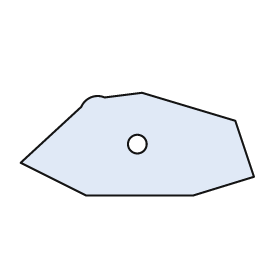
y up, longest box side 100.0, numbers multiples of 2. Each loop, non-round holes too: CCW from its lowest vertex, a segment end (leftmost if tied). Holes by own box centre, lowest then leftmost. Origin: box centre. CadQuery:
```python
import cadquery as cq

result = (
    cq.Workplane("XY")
    .moveTo(-22.0, -22.0)
    .lineTo(24.0, -22.0)
    .lineTo(50.0, -14.0)
    .lineTo(42.0, 10.0)
    .lineTo(2.0, 22.0)
    .lineTo(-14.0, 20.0)
    .threePointArc((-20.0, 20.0), (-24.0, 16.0))
    .lineTo(-50.0, -8.0)
    .close()
    .moveTo(0.0, 0.0)
    .circle(4.0)
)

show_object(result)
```